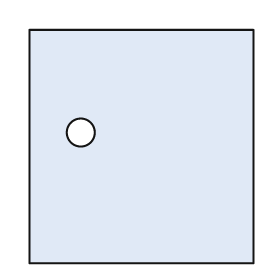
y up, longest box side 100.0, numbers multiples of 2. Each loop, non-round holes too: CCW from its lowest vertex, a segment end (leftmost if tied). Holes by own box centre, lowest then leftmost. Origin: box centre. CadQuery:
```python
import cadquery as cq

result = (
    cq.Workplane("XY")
    .moveTo(-48.0, -50.0)
    .lineTo(48.0, -50.0)
    .lineTo(48.0, 50.0)
    .lineTo(-48.0, 50.0)
    .close()
    .moveTo(-26.0, 6.0)
    .circle(6.0)
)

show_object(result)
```